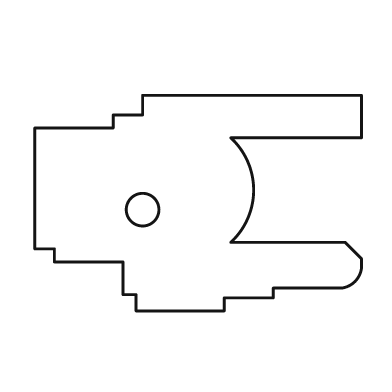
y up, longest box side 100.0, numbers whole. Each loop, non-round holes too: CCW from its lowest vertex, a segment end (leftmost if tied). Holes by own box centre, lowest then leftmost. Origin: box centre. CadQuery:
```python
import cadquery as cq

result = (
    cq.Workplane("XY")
    .moveTo(-19.0, -33.0)
    .lineTo(8.0, -33.0)
    .lineTo(8.0, -29.0)
    .lineTo(23.0, -29.0)
    .lineTo(23.0, -26.0)
    .lineTo(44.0, -26.0)
    .threePointArc((48.0, -24.0), (50.0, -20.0))
    .lineTo(50.0, -17.0)
    .lineTo(45.0, -12.0)
    .lineTo(10.0, -12.0)
    .threePointArc((17.0, 4.0), (10.0, 20.0))
    .lineTo(50.0, 20.0)
    .lineTo(50.0, 33.0)
    .lineTo(-17.0, 33.0)
    .lineTo(-17.0, 27.0)
    .lineTo(-26.0, 27.0)
    .lineTo(-26.0, 23.0)
    .lineTo(-50.0, 23.0)
    .lineTo(-50.0, -14.0)
    .lineTo(-44.0, -14.0)
    .lineTo(-44.0, -18.0)
    .lineTo(-23.0, -18.0)
    .lineTo(-23.0, -28.0)
    .lineTo(-19.0, -28.0)
    .close()
    .moveTo(-17.0, -2.0)
    .circle(5.0)
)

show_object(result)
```